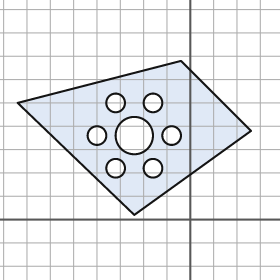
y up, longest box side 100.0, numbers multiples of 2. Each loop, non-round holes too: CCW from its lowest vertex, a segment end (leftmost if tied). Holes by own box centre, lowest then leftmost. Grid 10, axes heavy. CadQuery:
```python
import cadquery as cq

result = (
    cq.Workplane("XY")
    .moveTo(-24.0, 2.0)
    .lineTo(26.0, 38.0)
    .lineTo(-4.0, 68.0)
    .lineTo(-74.0, 50.0)
    .close()
    .moveTo(-32.0, 22.0)
    .circle(4.0)
    .moveTo(-16.0, 22.0)
    .circle(4.0)
    .moveTo(-40.0, 36.0)
    .circle(4.0)
    .moveTo(-24.0, 36.0)
    .circle(8.0)
    .moveTo(-8.0, 36.0)
    .circle(4.0)
    .moveTo(-32.0, 50.0)
    .circle(4.0)
    .moveTo(-16.0, 50.0)
    .circle(4.0)
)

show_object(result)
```